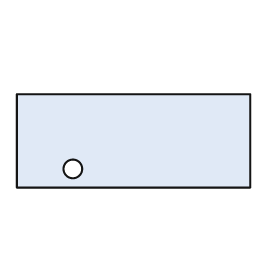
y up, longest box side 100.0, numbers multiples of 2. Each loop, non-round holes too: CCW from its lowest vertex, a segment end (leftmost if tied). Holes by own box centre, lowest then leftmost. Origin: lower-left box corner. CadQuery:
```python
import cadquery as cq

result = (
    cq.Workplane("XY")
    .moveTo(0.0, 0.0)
    .lineTo(100.0, 0.0)
    .lineTo(100.0, 40.0)
    .lineTo(0.0, 40.0)
    .close()
    .moveTo(24.0, 8.0)
    .circle(4.0)
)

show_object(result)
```